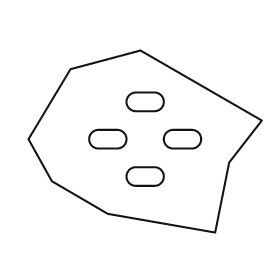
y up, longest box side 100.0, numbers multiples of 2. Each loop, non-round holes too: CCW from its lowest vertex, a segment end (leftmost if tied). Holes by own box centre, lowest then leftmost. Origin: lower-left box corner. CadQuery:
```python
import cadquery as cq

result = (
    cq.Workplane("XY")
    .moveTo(80.0, 0.0)
    .lineTo(86.0, 30.0)
    .lineTo(100.0, 48.0)
    .lineTo(48.0, 78.0)
    .lineTo(18.0, 70.0)
    .lineTo(0.0, 40.0)
    .lineTo(10.0, 22.0)
    .lineTo(34.0, 8.0)
    .close()
    .moveTo(46.0, 20.0)
    .lineTo(54.0, 20.0)
    .threePointArc((58.0, 24.0), (54.0, 28.0))
    .lineTo(46.0, 28.0)
    .threePointArc((42.0, 24.0), (46.0, 20.0))
    .close()
    .moveTo(30.0, 36.0)
    .lineTo(38.0, 36.0)
    .threePointArc((42.0, 40.0), (38.0, 44.0))
    .lineTo(30.0, 44.0)
    .threePointArc((26.0, 40.0), (30.0, 36.0))
    .close()
    .moveTo(62.0, 36.0)
    .lineTo(70.0, 36.0)
    .threePointArc((74.0, 40.0), (70.0, 44.0))
    .lineTo(62.0, 44.0)
    .threePointArc((58.0, 40.0), (62.0, 36.0))
    .close()
    .moveTo(46.0, 52.0)
    .lineTo(54.0, 52.0)
    .threePointArc((58.0, 56.0), (54.0, 60.0))
    .lineTo(46.0, 60.0)
    .threePointArc((42.0, 56.0), (46.0, 52.0))
    .close()
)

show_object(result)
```